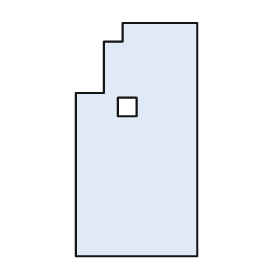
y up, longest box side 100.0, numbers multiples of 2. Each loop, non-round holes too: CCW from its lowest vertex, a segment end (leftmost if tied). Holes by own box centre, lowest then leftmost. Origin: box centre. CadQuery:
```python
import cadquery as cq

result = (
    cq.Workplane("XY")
    .moveTo(-26.0, -50.0)
    .lineTo(26.0, -50.0)
    .lineTo(26.0, 50.0)
    .lineTo(-6.0, 50.0)
    .lineTo(-6.0, 42.0)
    .lineTo(-14.0, 42.0)
    .lineTo(-14.0, 20.0)
    .lineTo(-26.0, 20.0)
    .close()
    .moveTo(-8.0, 10.0)
    .lineTo(0.0, 10.0)
    .lineTo(0.0, 18.0)
    .lineTo(-8.0, 18.0)
    .close()
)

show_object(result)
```